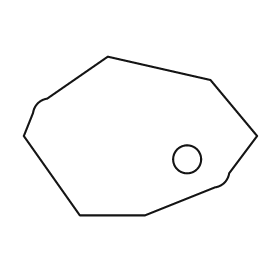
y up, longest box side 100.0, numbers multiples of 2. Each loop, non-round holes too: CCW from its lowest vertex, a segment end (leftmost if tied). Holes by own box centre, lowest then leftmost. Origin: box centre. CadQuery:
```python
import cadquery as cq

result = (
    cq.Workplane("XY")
    .moveTo(-26.0, -34.0)
    .lineTo(2.0, -34.0)
    .lineTo(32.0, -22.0)
    .threePointArc((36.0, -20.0), (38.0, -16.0))
    .lineTo(50.0, 0.0)
    .lineTo(30.0, 24.0)
    .lineTo(-14.0, 34.0)
    .lineTo(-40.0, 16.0)
    .threePointArc((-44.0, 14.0), (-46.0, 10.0))
    .lineTo(-50.0, 0.0)
    .close()
    .moveTo(20.0, -10.0)
    .circle(6.0)
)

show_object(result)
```